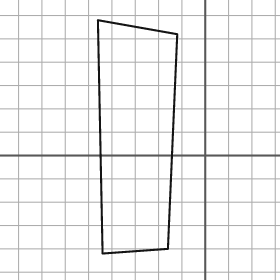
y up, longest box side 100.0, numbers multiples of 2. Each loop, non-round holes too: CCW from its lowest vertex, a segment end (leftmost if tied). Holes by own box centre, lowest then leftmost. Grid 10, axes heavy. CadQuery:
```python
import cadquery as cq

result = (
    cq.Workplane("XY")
    .moveTo(-44.0, -42.0)
    .lineTo(-16.0, -40.0)
    .lineTo(-12.0, 52.0)
    .lineTo(-46.0, 58.0)
    .close()
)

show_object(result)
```